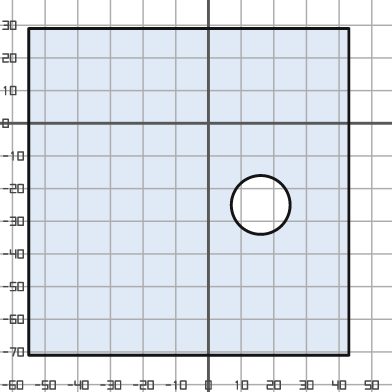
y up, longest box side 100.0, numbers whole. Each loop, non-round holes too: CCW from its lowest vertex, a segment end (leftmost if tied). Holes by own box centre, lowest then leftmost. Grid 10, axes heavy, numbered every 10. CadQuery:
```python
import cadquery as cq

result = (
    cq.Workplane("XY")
    .moveTo(-55.0, -71.0)
    .lineTo(43.0, -71.0)
    .lineTo(43.0, 29.0)
    .lineTo(-55.0, 29.0)
    .close()
    .moveTo(16.0, -25.0)
    .circle(9.0)
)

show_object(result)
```